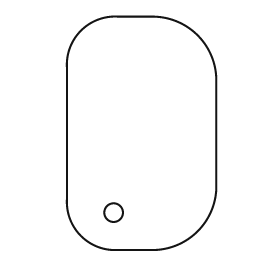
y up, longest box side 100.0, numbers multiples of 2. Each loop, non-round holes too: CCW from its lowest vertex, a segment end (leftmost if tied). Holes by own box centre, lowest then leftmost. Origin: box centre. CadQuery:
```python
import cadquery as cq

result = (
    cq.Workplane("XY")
    .moveTo(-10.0, -50.0)
    .lineTo(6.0, -50.0)
    .threePointArc((24.0, -42.0), (32.0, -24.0))
    .lineTo(32.0, 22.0)
    .threePointArc((24.0, 42.0), (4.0, 50.0))
    .lineTo(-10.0, 50.0)
    .threePointArc((-26.0, 44.0), (-32.0, 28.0))
    .lineTo(-32.0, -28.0)
    .threePointArc((-26.0, -44.0), (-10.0, -50.0))
    .close()
    .moveTo(-12.0, -34.0)
    .circle(4.0)
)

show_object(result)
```